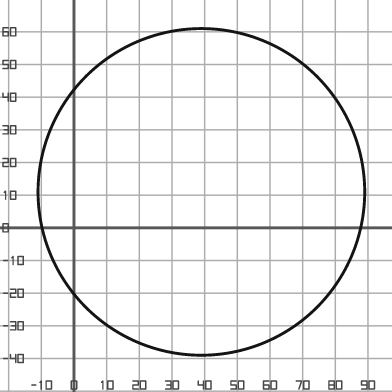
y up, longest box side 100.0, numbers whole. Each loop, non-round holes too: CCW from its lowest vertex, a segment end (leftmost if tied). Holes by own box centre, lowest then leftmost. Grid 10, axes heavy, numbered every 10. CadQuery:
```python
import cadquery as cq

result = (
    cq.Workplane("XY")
    .moveTo(39.0, 11.0)
    .circle(50.0)
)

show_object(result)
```